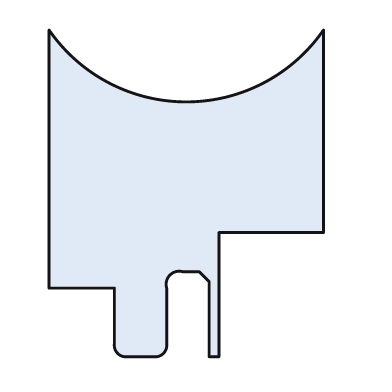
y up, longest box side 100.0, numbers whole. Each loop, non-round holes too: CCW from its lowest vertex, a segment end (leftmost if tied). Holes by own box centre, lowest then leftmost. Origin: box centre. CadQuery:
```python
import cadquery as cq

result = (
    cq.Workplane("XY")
    .moveTo(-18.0, -50.0)
    .lineTo(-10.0, -50.0)
    .threePointArc((-7.0, -49.0), (-6.0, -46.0))
    .lineTo(-6.0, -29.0)
    .threePointArc((-5.0, -25.0), (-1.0, -24.0))
    .lineTo(4.0, -24.0)
    .lineTo(7.0, -27.0)
    .lineTo(7.0, -50.0)
    .lineTo(10.0, -50.0)
    .lineTo(10.0, -12.0)
    .lineTo(42.0, -12.0)
    .lineTo(42.0, 50.0)
    .threePointArc((0.0, 28.0), (-42.0, 50.0))
    .lineTo(-42.0, -29.0)
    .lineTo(-22.0, -29.0)
    .lineTo(-22.0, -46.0)
    .threePointArc((-21.0, -49.0), (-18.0, -50.0))
    .close()
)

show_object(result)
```